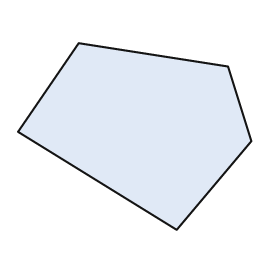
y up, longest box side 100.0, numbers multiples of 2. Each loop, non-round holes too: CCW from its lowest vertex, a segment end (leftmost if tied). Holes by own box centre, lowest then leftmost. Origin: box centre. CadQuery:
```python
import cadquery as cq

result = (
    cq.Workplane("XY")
    .moveTo(18.0, -40.0)
    .lineTo(50.0, -2.0)
    .lineTo(40.0, 30.0)
    .lineTo(-24.0, 40.0)
    .lineTo(-50.0, 2.0)
    .close()
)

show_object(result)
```